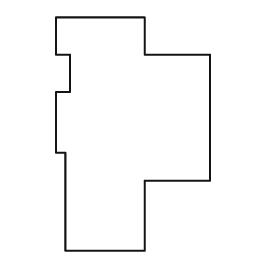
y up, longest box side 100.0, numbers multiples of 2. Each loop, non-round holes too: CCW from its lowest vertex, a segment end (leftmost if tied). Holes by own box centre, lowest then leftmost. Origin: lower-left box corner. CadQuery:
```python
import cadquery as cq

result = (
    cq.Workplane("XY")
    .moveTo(4.0, 0.0)
    .lineTo(38.0, 0.0)
    .lineTo(38.0, 30.0)
    .lineTo(66.0, 30.0)
    .lineTo(66.0, 84.0)
    .lineTo(38.0, 84.0)
    .lineTo(38.0, 100.0)
    .lineTo(0.0, 100.0)
    .lineTo(0.0, 84.0)
    .lineTo(6.0, 84.0)
    .lineTo(6.0, 68.0)
    .lineTo(0.0, 68.0)
    .lineTo(0.0, 42.0)
    .lineTo(4.0, 42.0)
    .close()
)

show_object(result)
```